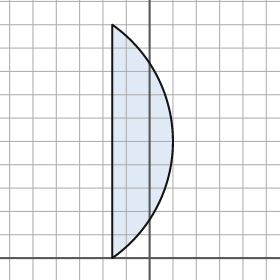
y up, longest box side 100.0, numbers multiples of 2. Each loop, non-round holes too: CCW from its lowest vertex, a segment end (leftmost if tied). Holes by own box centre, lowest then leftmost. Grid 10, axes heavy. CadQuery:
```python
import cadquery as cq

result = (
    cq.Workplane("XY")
    .moveTo(-16.0, 0.0)
    .threePointArc((10.0, 50.0), (-16.0, 100.0))
    .close()
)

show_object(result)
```